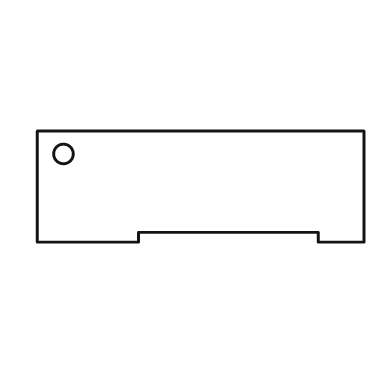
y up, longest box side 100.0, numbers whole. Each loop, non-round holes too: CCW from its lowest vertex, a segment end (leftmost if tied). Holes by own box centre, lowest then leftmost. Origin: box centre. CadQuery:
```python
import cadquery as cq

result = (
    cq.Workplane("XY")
    .moveTo(-50.0, -17.0)
    .lineTo(-19.0, -17.0)
    .lineTo(-19.0, -14.0)
    .lineTo(36.0, -14.0)
    .lineTo(36.0, -17.0)
    .lineTo(50.0, -17.0)
    .lineTo(50.0, 17.0)
    .lineTo(-50.0, 17.0)
    .close()
    .moveTo(-42.0, 10.0)
    .circle(3.0)
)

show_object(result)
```